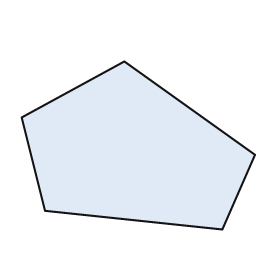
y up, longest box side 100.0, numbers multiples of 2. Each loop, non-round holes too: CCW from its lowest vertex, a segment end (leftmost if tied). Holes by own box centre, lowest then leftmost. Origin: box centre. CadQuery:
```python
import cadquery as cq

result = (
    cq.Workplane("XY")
    .moveTo(36.0, -36.0)
    .lineTo(50.0, -4.0)
    .lineTo(-6.0, 36.0)
    .lineTo(-50.0, 12.0)
    .lineTo(-40.0, -28.0)
    .close()
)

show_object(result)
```